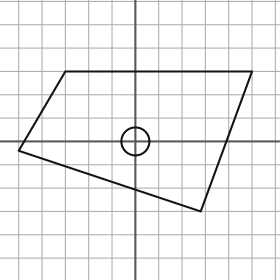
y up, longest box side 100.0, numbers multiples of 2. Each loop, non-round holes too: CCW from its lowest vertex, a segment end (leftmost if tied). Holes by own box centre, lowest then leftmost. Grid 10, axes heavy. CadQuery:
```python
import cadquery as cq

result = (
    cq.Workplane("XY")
    .moveTo(28.0, -30.0)
    .lineTo(50.0, 30.0)
    .lineTo(-30.0, 30.0)
    .lineTo(-50.0, -4.0)
    .close()
    .moveTo(0.0, 0.0)
    .circle(6.0)
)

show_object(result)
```